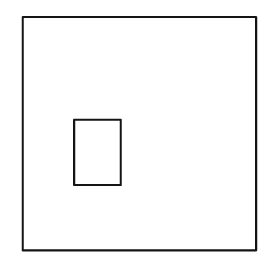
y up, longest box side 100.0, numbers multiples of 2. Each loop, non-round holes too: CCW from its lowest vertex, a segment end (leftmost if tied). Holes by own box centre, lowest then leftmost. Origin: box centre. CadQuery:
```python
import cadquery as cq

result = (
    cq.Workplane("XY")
    .moveTo(-50.0, -50.0)
    .lineTo(50.0, -50.0)
    .lineTo(50.0, 50.0)
    .lineTo(-50.0, 50.0)
    .close()
    .moveTo(-28.0, -22.0)
    .lineTo(-8.0, -22.0)
    .lineTo(-8.0, 6.0)
    .lineTo(-28.0, 6.0)
    .close()
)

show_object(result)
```